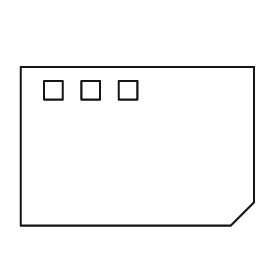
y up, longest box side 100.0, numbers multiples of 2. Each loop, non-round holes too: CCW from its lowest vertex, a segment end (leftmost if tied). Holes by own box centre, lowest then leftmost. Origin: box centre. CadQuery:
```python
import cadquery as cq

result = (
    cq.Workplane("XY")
    .moveTo(-50.0, -34.0)
    .lineTo(40.0, -34.0)
    .lineTo(50.0, -24.0)
    .lineTo(50.0, 34.0)
    .lineTo(-50.0, 34.0)
    .close()
    .moveTo(-40.0, 20.0)
    .lineTo(-32.0, 20.0)
    .lineTo(-32.0, 28.0)
    .lineTo(-40.0, 28.0)
    .close()
    .moveTo(-24.0, 20.0)
    .lineTo(-16.0, 20.0)
    .lineTo(-16.0, 28.0)
    .lineTo(-24.0, 28.0)
    .close()
    .moveTo(-8.0, 20.0)
    .lineTo(0.0, 20.0)
    .lineTo(0.0, 28.0)
    .lineTo(-8.0, 28.0)
    .close()
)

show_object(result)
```